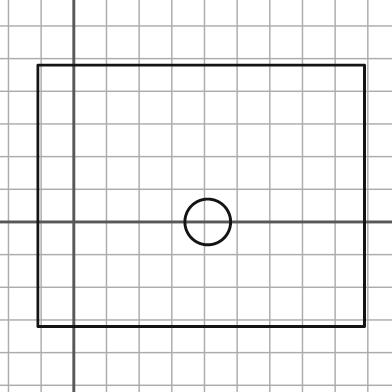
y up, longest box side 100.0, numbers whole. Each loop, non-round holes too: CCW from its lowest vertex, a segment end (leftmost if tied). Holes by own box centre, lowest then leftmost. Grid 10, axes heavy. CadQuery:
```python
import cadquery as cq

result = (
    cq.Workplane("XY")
    .moveTo(-11.0, -32.0)
    .lineTo(89.0, -32.0)
    .lineTo(89.0, 48.0)
    .lineTo(-11.0, 48.0)
    .close()
    .moveTo(41.0, 0.0)
    .circle(7.0)
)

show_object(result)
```